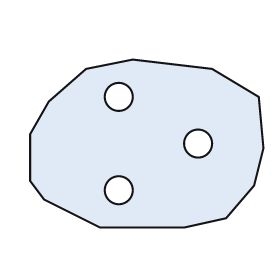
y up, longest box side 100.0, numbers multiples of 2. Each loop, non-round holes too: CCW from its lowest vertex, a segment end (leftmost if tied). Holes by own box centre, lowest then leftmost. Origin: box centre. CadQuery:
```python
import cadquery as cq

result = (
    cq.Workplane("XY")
    .moveTo(-20.0, -36.0)
    .lineTo(16.0, -36.0)
    .lineTo(34.0, -32.0)
    .lineTo(46.0, -18.0)
    .lineTo(50.0, -2.0)
    .lineTo(48.0, 20.0)
    .lineTo(28.0, 32.0)
    .lineTo(-6.0, 36.0)
    .lineTo(-26.0, 32.0)
    .lineTo(-42.0, 18.0)
    .lineTo(-50.0, 4.0)
    .lineTo(-50.0, -16.0)
    .lineTo(-44.0, -24.0)
    .close()
    .moveTo(-12.0, -20.0)
    .circle(6.0)
    .moveTo(22.0, 0.0)
    .circle(6.0)
    .moveTo(-12.0, 20.0)
    .circle(6.0)
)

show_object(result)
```